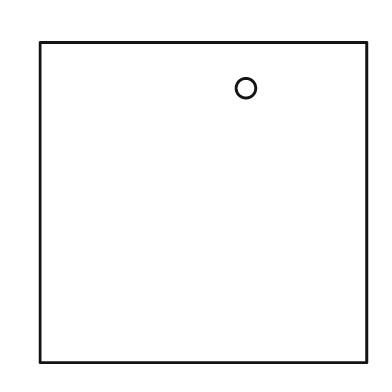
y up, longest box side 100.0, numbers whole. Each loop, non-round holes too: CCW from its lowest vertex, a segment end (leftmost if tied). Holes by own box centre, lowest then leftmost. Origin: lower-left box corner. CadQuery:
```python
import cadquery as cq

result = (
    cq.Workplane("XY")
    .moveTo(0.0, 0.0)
    .lineTo(100.0, 0.0)
    .lineTo(100.0, 98.0)
    .lineTo(0.0, 98.0)
    .close()
    .moveTo(63.0, 84.0)
    .circle(3.0)
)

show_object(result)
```